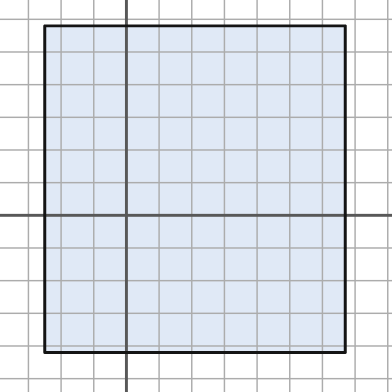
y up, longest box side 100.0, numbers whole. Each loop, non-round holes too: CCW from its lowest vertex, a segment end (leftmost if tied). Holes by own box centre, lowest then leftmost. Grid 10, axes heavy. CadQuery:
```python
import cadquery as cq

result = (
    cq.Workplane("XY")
    .moveTo(-25.0, -42.0)
    .lineTo(67.0, -42.0)
    .lineTo(67.0, 58.0)
    .lineTo(-25.0, 58.0)
    .close()
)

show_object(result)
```